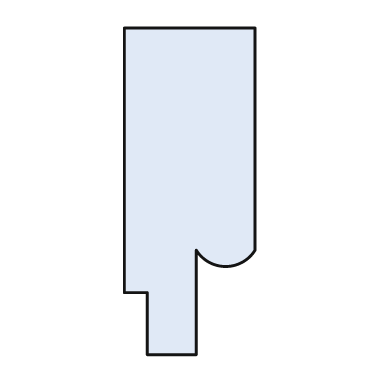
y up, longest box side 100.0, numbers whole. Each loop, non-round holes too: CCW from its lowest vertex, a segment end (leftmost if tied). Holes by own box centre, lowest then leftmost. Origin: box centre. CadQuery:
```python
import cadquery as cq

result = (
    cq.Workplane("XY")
    .moveTo(-13.0, -50.0)
    .lineTo(2.0, -50.0)
    .lineTo(2.0, -18.0)
    .threePointArc((11.0, -23.0), (20.0, -18.0))
    .lineTo(20.0, 50.0)
    .lineTo(-20.0, 50.0)
    .lineTo(-20.0, -31.0)
    .lineTo(-13.0, -31.0)
    .close()
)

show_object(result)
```